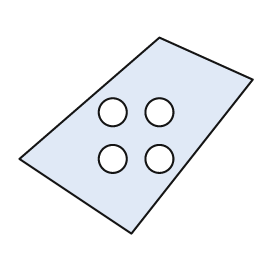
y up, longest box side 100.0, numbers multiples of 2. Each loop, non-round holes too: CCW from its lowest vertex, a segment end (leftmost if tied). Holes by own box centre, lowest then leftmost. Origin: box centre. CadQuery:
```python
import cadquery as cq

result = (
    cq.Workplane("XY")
    .moveTo(-2.0, -42.0)
    .lineTo(50.0, 24.0)
    .lineTo(10.0, 42.0)
    .lineTo(-50.0, -10.0)
    .close()
    .moveTo(-10.0, -10.0)
    .circle(6.0)
    .moveTo(10.0, -10.0)
    .circle(6.0)
    .moveTo(-10.0, 10.0)
    .circle(6.0)
    .moveTo(10.0, 10.0)
    .circle(6.0)
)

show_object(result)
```